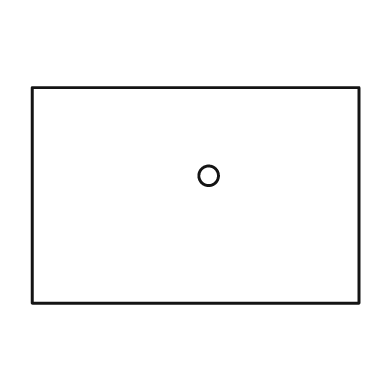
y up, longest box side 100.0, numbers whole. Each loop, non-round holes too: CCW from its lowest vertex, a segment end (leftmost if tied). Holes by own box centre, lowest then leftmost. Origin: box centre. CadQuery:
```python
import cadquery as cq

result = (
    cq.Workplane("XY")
    .moveTo(-50.0, -33.0)
    .lineTo(50.0, -33.0)
    .lineTo(50.0, 33.0)
    .lineTo(-50.0, 33.0)
    .close()
    .moveTo(4.0, 6.0)
    .circle(3.0)
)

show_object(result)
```